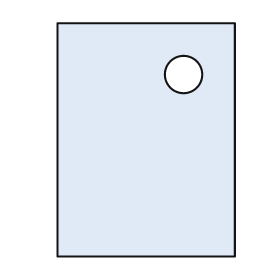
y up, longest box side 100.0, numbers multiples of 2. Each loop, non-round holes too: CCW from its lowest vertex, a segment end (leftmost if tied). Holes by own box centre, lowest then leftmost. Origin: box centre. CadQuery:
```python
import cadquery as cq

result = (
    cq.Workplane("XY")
    .moveTo(-38.0, -50.0)
    .lineTo(38.0, -50.0)
    .lineTo(38.0, 50.0)
    .lineTo(-38.0, 50.0)
    .close()
    .moveTo(16.0, 28.0)
    .circle(8.0)
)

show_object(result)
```